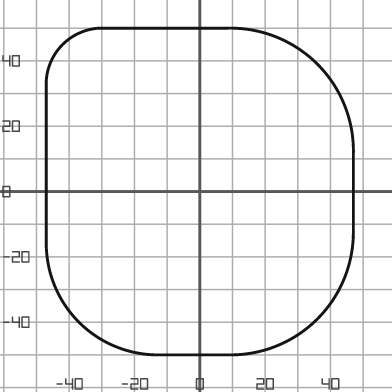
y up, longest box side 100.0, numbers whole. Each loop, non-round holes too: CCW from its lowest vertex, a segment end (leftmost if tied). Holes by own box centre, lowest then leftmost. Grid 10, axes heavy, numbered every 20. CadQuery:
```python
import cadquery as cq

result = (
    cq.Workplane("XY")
    .moveTo(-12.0, -50.0)
    .lineTo(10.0, -50.0)
    .threePointArc((36.0, -39.0), (47.0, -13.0))
    .lineTo(47.0, 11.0)
    .threePointArc((36.0, 39.0), (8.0, 50.0))
    .lineTo(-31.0, 50.0)
    .threePointArc((-42.0, 45.0), (-47.0, 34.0))
    .lineTo(-47.0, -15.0)
    .threePointArc((-37.0, -40.0), (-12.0, -50.0))
    .close()
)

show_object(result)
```